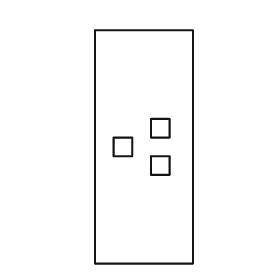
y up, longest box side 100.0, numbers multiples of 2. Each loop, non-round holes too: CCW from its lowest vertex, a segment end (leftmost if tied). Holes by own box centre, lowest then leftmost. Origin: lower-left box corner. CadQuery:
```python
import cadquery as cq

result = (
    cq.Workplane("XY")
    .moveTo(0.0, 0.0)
    .lineTo(42.0, 0.0)
    .lineTo(42.0, 100.0)
    .lineTo(0.0, 100.0)
    .close()
    .moveTo(24.0, 38.0)
    .lineTo(32.0, 38.0)
    .lineTo(32.0, 46.0)
    .lineTo(24.0, 46.0)
    .close()
    .moveTo(8.0, 46.0)
    .lineTo(16.0, 46.0)
    .lineTo(16.0, 54.0)
    .lineTo(8.0, 54.0)
    .close()
    .moveTo(24.0, 54.0)
    .lineTo(32.0, 54.0)
    .lineTo(32.0, 62.0)
    .lineTo(24.0, 62.0)
    .close()
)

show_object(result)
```